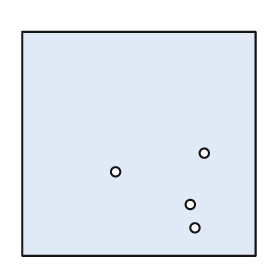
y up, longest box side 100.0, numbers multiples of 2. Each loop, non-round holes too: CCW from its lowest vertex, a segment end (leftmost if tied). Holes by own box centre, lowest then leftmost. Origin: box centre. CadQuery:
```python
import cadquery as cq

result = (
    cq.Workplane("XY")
    .moveTo(-50.0, -48.0)
    .lineTo(50.0, -48.0)
    .lineTo(50.0, 48.0)
    .lineTo(-50.0, 48.0)
    .close()
    .moveTo(24.0, -36.0)
    .circle(2.0)
    .moveTo(22.0, -26.0)
    .circle(2.0)
    .moveTo(-10.0, -12.0)
    .circle(2.0)
    .moveTo(28.0, -4.0)
    .circle(2.0)
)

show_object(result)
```